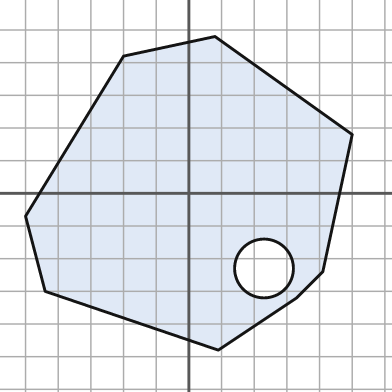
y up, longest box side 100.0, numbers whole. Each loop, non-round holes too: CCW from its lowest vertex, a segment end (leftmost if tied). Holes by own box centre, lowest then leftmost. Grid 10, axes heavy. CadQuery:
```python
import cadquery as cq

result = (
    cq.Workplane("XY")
    .moveTo(9.0, -48.0)
    .lineTo(33.0, -32.0)
    .lineTo(41.0, -24.0)
    .lineTo(50.0, 18.0)
    .lineTo(8.0, 48.0)
    .lineTo(-20.0, 42.0)
    .lineTo(-50.0, -7.0)
    .lineTo(-44.0, -30.0)
    .close()
    .moveTo(23.0, -23.0)
    .circle(9.0)
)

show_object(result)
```